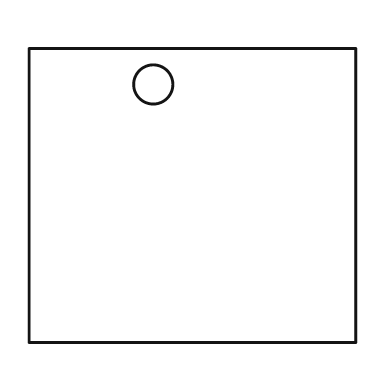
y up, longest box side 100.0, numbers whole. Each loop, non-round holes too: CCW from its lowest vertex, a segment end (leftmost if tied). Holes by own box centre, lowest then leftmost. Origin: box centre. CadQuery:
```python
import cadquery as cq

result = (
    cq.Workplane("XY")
    .moveTo(-50.0, -45.0)
    .lineTo(50.0, -45.0)
    .lineTo(50.0, 45.0)
    .lineTo(-50.0, 45.0)
    .close()
    .moveTo(-12.0, 34.0)
    .circle(6.0)
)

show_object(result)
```